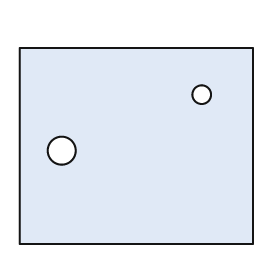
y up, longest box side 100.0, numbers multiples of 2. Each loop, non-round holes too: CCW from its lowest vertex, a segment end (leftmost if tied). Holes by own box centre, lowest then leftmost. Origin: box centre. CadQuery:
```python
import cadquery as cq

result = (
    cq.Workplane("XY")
    .moveTo(-50.0, -42.0)
    .lineTo(50.0, -42.0)
    .lineTo(50.0, 42.0)
    .lineTo(-50.0, 42.0)
    .close()
    .moveTo(-32.0, -2.0)
    .circle(6.0)
    .moveTo(28.0, 22.0)
    .circle(4.0)
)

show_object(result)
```